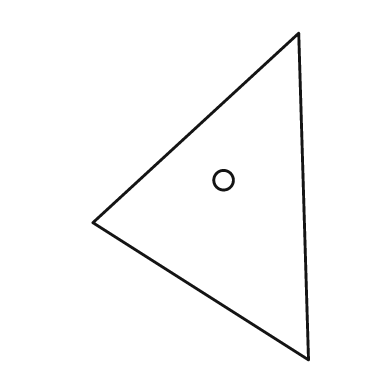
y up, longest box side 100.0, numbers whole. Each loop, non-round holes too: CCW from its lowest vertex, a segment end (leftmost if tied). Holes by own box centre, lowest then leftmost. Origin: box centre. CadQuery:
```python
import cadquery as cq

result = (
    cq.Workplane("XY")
    .moveTo(33.0, -50.0)
    .lineTo(30.0, 50.0)
    .lineTo(-33.0, -8.0)
    .close()
    .moveTo(7.0, 5.0)
    .circle(3.0)
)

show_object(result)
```